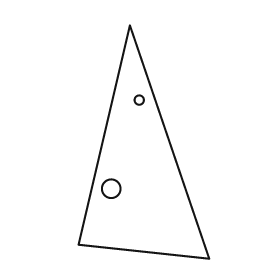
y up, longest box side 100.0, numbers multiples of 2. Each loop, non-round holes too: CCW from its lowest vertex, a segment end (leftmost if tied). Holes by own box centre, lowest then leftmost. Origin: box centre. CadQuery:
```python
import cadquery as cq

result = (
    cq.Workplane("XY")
    .moveTo(28.0, -50.0)
    .lineTo(-6.0, 50.0)
    .lineTo(-28.0, -44.0)
    .close()
    .moveTo(-14.0, -20.0)
    .circle(4.0)
    .moveTo(-2.0, 18.0)
    .circle(2.0)
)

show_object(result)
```